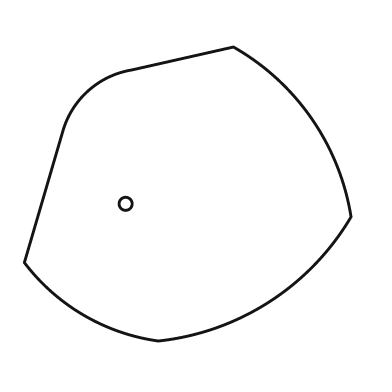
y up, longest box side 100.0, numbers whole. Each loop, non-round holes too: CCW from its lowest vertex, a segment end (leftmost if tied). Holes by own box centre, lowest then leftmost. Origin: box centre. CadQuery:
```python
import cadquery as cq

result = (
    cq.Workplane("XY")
    .moveTo(-9.0, -45.0)
    .threePointArc((25.0, -33.0), (50.0, -7.0))
    .threePointArc((38.0, 23.0), (14.0, 45.0))
    .lineTo(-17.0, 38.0)
    .threePointArc((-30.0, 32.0), (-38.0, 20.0))
    .lineTo(-50.0, -21.0)
    .threePointArc((-32.0, -37.0), (-9.0, -45.0))
    .close()
    .moveTo(-19.0, -3.0)
    .circle(2.0)
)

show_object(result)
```